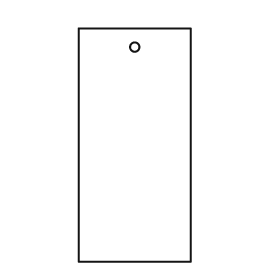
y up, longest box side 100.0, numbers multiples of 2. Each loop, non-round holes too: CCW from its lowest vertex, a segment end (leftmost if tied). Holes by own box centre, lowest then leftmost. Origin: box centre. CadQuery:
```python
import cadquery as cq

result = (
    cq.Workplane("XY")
    .moveTo(-24.0, -50.0)
    .lineTo(24.0, -50.0)
    .lineTo(24.0, 50.0)
    .lineTo(-24.0, 50.0)
    .close()
    .moveTo(0.0, 42.0)
    .circle(2.0)
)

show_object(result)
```